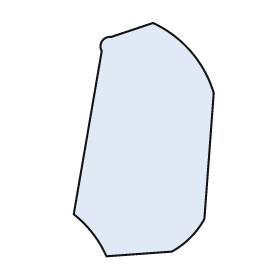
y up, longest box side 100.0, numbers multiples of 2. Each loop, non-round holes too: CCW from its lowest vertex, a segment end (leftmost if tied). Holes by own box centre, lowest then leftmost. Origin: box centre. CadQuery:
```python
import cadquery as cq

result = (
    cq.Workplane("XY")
    .moveTo(-16.0, -50.0)
    .lineTo(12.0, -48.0)
    .threePointArc((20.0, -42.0), (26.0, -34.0))
    .lineTo(30.0, 20.0)
    .threePointArc((20.0, 38.0), (4.0, 50.0))
    .lineTo(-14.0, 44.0)
    .threePointArc((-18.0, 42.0), (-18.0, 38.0))
    .lineTo(-30.0, -32.0)
    .threePointArc((-22.0, -40.0), (-16.0, -50.0))
    .close()
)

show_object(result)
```